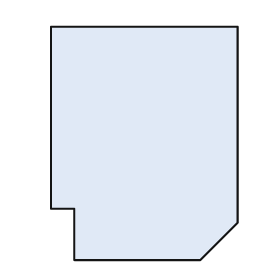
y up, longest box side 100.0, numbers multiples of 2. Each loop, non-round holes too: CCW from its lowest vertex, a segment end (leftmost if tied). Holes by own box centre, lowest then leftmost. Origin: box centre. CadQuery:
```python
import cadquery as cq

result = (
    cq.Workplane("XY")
    .moveTo(-30.0, -50.0)
    .lineTo(24.0, -50.0)
    .lineTo(40.0, -34.0)
    .lineTo(40.0, 50.0)
    .lineTo(-40.0, 50.0)
    .lineTo(-40.0, -28.0)
    .lineTo(-30.0, -28.0)
    .close()
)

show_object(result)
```